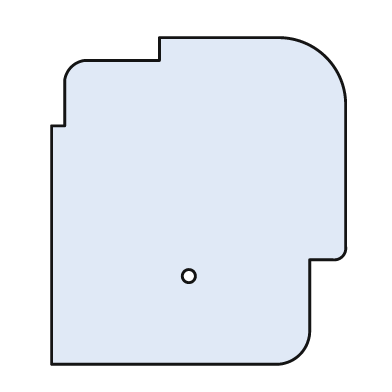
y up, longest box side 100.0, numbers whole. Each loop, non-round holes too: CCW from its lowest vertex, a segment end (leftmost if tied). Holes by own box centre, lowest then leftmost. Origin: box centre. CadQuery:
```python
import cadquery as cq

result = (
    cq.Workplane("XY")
    .moveTo(-45.0, -50.0)
    .lineTo(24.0, -50.0)
    .threePointArc((31.0, -47.0), (34.0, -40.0))
    .lineTo(34.0, -18.0)
    .lineTo(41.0, -18.0)
    .threePointArc((44.0, -17.0), (45.0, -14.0))
    .lineTo(45.0, 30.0)
    .threePointArc((39.0, 44.0), (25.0, 50.0))
    .lineTo(-12.0, 50.0)
    .lineTo(-12.0, 43.0)
    .lineTo(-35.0, 43.0)
    .threePointArc((-39.0, 41.0), (-41.0, 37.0))
    .lineTo(-41.0, 23.0)
    .lineTo(-45.0, 23.0)
    .close()
    .moveTo(-3.0, -23.0)
    .circle(2.0)
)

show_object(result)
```